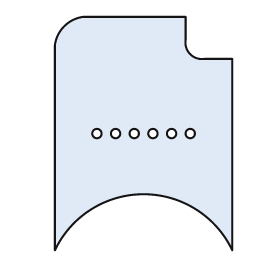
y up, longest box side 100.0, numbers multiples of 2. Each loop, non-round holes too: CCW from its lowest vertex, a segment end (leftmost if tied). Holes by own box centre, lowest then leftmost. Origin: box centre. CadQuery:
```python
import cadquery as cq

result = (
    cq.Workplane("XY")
    .moveTo(-38.0, -50.0)
    .threePointArc((0.0, -26.0), (38.0, -50.0))
    .lineTo(38.0, 32.0)
    .lineTo(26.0, 32.0)
    .threePointArc((20.0, 34.0), (18.0, 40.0))
    .lineTo(18.0, 50.0)
    .lineTo(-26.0, 50.0)
    .threePointArc((-34.0, 46.0), (-38.0, 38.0))
    .close()
    .moveTo(-20.0, 0.0)
    .circle(2.0)
    .moveTo(-12.0, 0.0)
    .circle(2.0)
    .moveTo(-4.0, 0.0)
    .circle(2.0)
    .moveTo(4.0, 0.0)
    .circle(2.0)
    .moveTo(12.0, 0.0)
    .circle(2.0)
    .moveTo(20.0, 0.0)
    .circle(2.0)
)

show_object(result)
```